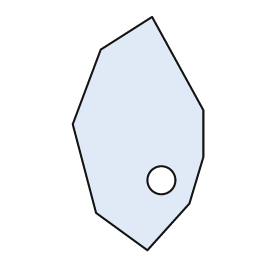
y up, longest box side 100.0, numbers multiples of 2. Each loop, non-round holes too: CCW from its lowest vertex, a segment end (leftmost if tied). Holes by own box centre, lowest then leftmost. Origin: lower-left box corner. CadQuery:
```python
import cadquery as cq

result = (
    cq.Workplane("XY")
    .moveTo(32.0, 0.0)
    .lineTo(50.0, 20.0)
    .lineTo(56.0, 40.0)
    .lineTo(56.0, 60.0)
    .lineTo(34.0, 100.0)
    .lineTo(12.0, 86.0)
    .lineTo(0.0, 54.0)
    .lineTo(10.0, 16.0)
    .close()
    .moveTo(38.0, 30.0)
    .circle(6.0)
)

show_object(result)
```